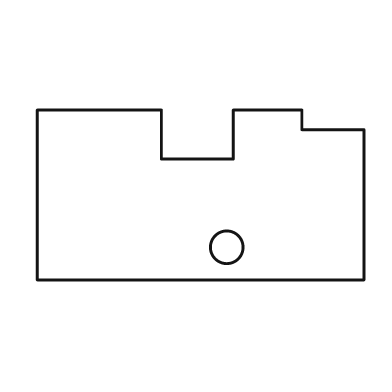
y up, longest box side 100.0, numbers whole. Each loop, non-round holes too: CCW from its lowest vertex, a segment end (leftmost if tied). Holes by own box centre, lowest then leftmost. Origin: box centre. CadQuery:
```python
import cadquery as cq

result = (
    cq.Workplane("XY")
    .moveTo(-50.0, -26.0)
    .lineTo(50.0, -26.0)
    .lineTo(50.0, 20.0)
    .lineTo(31.0, 20.0)
    .lineTo(31.0, 26.0)
    .lineTo(10.0, 26.0)
    .lineTo(10.0, 11.0)
    .lineTo(-12.0, 11.0)
    .lineTo(-12.0, 26.0)
    .lineTo(-50.0, 26.0)
    .close()
    .moveTo(8.0, -16.0)
    .circle(5.0)
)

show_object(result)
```